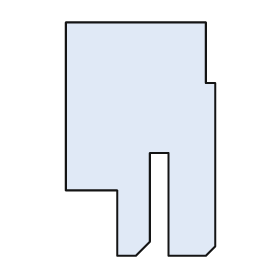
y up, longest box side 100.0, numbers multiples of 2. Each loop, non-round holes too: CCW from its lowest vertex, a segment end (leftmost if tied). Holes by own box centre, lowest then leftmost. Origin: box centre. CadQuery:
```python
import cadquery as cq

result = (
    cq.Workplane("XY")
    .moveTo(-10.0, -50.0)
    .lineTo(-2.0, -50.0)
    .lineTo(4.0, -44.0)
    .lineTo(4.0, -6.0)
    .lineTo(12.0, -6.0)
    .lineTo(12.0, -50.0)
    .lineTo(28.0, -50.0)
    .lineTo(32.0, -46.0)
    .lineTo(32.0, 24.0)
    .lineTo(28.0, 24.0)
    .lineTo(28.0, 50.0)
    .lineTo(-32.0, 50.0)
    .lineTo(-32.0, -22.0)
    .lineTo(-10.0, -22.0)
    .close()
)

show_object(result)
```